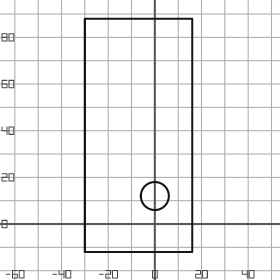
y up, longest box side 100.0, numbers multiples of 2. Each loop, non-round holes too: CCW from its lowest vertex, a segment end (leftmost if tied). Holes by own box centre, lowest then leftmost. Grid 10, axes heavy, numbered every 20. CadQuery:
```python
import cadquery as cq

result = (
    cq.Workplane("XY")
    .moveTo(-30.0, -12.0)
    .lineTo(16.0, -12.0)
    .lineTo(16.0, 88.0)
    .lineTo(-30.0, 88.0)
    .close()
    .moveTo(0.0, 12.0)
    .circle(6.0)
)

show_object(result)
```